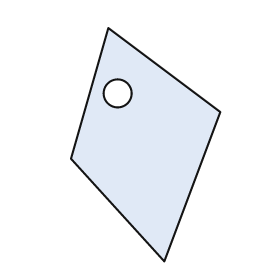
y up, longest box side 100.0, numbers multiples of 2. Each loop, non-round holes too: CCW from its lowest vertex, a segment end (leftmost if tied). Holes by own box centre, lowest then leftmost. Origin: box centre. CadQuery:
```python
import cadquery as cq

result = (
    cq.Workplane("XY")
    .moveTo(8.0, -50.0)
    .lineTo(32.0, 14.0)
    .lineTo(-16.0, 50.0)
    .lineTo(-32.0, -6.0)
    .close()
    .moveTo(-12.0, 22.0)
    .circle(6.0)
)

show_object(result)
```